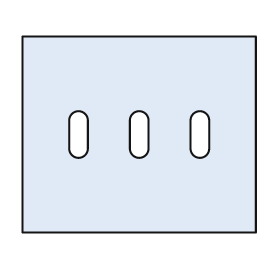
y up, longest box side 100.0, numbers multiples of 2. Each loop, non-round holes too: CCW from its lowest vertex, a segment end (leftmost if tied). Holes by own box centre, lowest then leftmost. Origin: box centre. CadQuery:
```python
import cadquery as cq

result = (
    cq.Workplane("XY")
    .moveTo(-50.0, -42.0)
    .lineTo(50.0, -42.0)
    .lineTo(50.0, 42.0)
    .lineTo(-50.0, 42.0)
    .close()
    .moveTo(-30.0, -6.0)
    .threePointArc((-26.0, -10.0), (-22.0, -6.0))
    .lineTo(-22.0, 6.0)
    .threePointArc((-26.0, 10.0), (-30.0, 6.0))
    .close()
    .moveTo(-4.0, -6.0)
    .threePointArc((0.0, -10.0), (4.0, -6.0))
    .lineTo(4.0, 6.0)
    .threePointArc((0.0, 10.0), (-4.0, 6.0))
    .close()
    .moveTo(22.0, -6.0)
    .threePointArc((26.0, -10.0), (30.0, -6.0))
    .lineTo(30.0, 6.0)
    .threePointArc((26.0, 10.0), (22.0, 6.0))
    .close()
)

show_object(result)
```